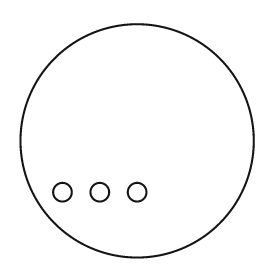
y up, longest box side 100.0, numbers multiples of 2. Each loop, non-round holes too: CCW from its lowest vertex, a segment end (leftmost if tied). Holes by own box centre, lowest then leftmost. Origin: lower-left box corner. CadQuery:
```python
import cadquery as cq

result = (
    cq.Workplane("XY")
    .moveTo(50.0, 50.0)
    .circle(50.0)
    .moveTo(18.0, 28.0)
    .circle(4.0)
    .moveTo(34.0, 28.0)
    .circle(4.0)
    .moveTo(50.0, 28.0)
    .circle(4.0)
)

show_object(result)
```